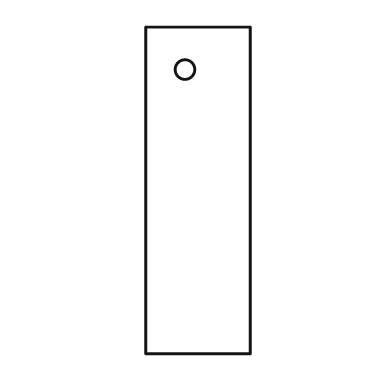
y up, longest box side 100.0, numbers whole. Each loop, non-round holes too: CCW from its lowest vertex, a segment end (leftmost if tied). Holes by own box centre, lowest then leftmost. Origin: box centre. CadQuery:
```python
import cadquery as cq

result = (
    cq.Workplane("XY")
    .moveTo(-16.0, -50.0)
    .lineTo(16.0, -50.0)
    .lineTo(16.0, 50.0)
    .lineTo(-16.0, 50.0)
    .close()
    .moveTo(-4.0, 37.0)
    .circle(3.0)
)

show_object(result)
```